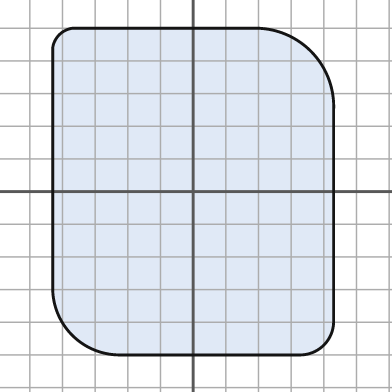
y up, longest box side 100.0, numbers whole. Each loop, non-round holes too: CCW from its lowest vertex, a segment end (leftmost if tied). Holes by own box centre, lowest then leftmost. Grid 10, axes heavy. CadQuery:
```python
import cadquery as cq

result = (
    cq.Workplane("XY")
    .moveTo(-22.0, -50.0)
    .lineTo(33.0, -50.0)
    .threePointArc((40.0, -47.0), (43.0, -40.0))
    .lineTo(43.0, 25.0)
    .threePointArc((36.0, 43.0), (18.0, 50.0))
    .lineTo(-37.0, 50.0)
    .threePointArc((-41.0, 48.0), (-43.0, 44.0))
    .lineTo(-43.0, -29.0)
    .threePointArc((-37.0, -44.0), (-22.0, -50.0))
    .close()
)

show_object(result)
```